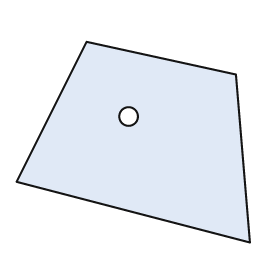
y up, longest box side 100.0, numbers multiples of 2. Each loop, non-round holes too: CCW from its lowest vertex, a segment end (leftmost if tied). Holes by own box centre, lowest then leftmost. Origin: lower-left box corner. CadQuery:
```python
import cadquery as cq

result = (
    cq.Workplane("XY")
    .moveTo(100.0, 0.0)
    .lineTo(94.0, 72.0)
    .lineTo(30.0, 86.0)
    .lineTo(0.0, 26.0)
    .close()
    .moveTo(48.0, 54.0)
    .circle(4.0)
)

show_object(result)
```